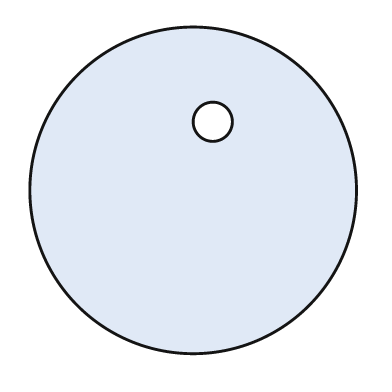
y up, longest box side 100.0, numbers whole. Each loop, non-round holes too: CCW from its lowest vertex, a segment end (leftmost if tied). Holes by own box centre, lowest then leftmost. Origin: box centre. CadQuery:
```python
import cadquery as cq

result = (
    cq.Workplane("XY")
    .moveTo(0.0, 0.0)
    .circle(50.0)
    .moveTo(6.0, 21.0)
    .circle(6.0)
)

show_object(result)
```